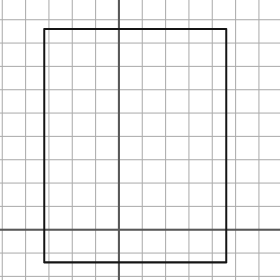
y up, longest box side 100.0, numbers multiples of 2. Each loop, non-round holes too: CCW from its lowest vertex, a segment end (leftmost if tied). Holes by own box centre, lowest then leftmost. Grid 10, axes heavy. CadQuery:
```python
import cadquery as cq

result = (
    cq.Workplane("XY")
    .moveTo(-32.0, -14.0)
    .lineTo(46.0, -14.0)
    .lineTo(46.0, 86.0)
    .lineTo(-32.0, 86.0)
    .close()
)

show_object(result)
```